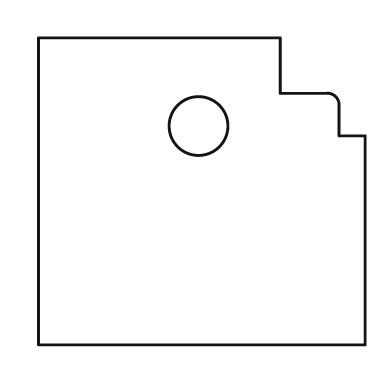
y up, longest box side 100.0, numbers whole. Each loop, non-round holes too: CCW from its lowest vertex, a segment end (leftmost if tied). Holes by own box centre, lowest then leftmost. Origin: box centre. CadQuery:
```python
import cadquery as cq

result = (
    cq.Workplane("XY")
    .moveTo(-50.0, -47.0)
    .lineTo(50.0, -47.0)
    .lineTo(50.0, 17.0)
    .lineTo(42.0, 17.0)
    .lineTo(42.0, 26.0)
    .threePointArc((41.0, 29.0), (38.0, 30.0))
    .lineTo(24.0, 30.0)
    .lineTo(24.0, 47.0)
    .lineTo(-50.0, 47.0)
    .close()
    .moveTo(-1.0, 20.0)
    .circle(9.0)
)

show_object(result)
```